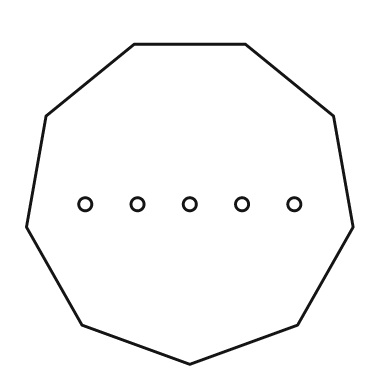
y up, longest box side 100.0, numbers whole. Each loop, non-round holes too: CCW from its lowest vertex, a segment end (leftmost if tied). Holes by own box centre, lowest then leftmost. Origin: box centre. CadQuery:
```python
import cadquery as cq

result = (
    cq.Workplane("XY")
    .moveTo(0.0, -49.0)
    .lineTo(33.0, -37.0)
    .lineTo(50.0, -7.0)
    .lineTo(44.0, 27.0)
    .lineTo(17.0, 49.0)
    .lineTo(-17.0, 49.0)
    .lineTo(-44.0, 27.0)
    .lineTo(-50.0, -7.0)
    .lineTo(-33.0, -37.0)
    .close()
    .moveTo(-32.0, 0.0)
    .circle(2.0)
    .moveTo(-16.0, 0.0)
    .circle(2.0)
    .moveTo(0.0, 0.0)
    .circle(2.0)
    .moveTo(16.0, 0.0)
    .circle(2.0)
    .moveTo(32.0, 0.0)
    .circle(2.0)
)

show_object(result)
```